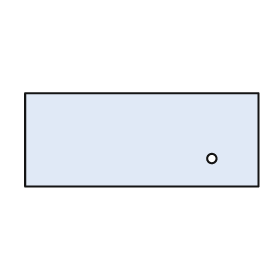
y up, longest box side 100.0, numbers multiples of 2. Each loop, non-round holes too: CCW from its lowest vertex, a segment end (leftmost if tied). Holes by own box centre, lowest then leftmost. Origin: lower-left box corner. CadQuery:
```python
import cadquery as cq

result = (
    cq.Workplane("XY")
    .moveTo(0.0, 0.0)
    .lineTo(100.0, 0.0)
    .lineTo(100.0, 40.0)
    .lineTo(0.0, 40.0)
    .close()
    .moveTo(80.0, 12.0)
    .circle(2.0)
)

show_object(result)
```